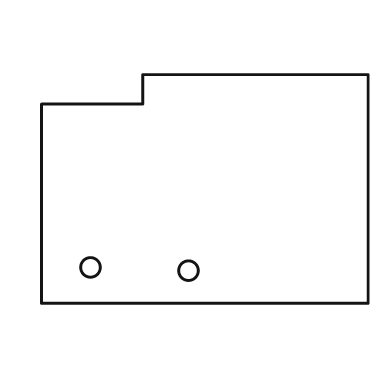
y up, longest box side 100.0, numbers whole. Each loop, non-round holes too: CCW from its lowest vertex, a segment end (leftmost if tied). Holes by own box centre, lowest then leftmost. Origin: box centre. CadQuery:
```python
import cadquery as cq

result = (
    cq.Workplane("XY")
    .moveTo(-50.0, -35.0)
    .lineTo(50.0, -35.0)
    .lineTo(50.0, 35.0)
    .lineTo(-19.0, 35.0)
    .lineTo(-19.0, 26.0)
    .lineTo(-50.0, 26.0)
    .close()
    .moveTo(-5.0, -25.0)
    .circle(3.0)
    .moveTo(-35.0, -24.0)
    .circle(3.0)
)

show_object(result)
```